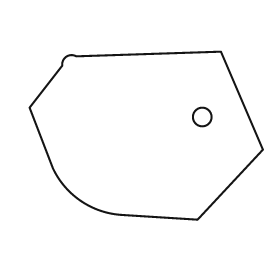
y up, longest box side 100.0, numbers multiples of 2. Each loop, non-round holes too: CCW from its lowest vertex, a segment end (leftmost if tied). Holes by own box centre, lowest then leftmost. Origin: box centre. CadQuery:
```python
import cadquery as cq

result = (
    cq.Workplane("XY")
    .moveTo(22.0, -36.0)
    .lineTo(50.0, -6.0)
    .lineTo(32.0, 36.0)
    .lineTo(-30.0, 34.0)
    .threePointArc((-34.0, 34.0), (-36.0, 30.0))
    .lineTo(-50.0, 12.0)
    .lineTo(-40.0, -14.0)
    .threePointArc((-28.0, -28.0), (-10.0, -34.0))
    .close()
    .moveTo(24.0, 8.0)
    .circle(4.0)
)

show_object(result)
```